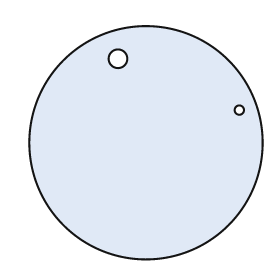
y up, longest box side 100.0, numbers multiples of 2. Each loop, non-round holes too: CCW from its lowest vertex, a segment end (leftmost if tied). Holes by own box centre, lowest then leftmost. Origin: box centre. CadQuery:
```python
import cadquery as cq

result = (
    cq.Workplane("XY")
    .moveTo(0.0, 0.0)
    .circle(50.0)
    .moveTo(40.0, 14.0)
    .circle(2.0)
    .moveTo(-12.0, 36.0)
    .circle(4.0)
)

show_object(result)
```